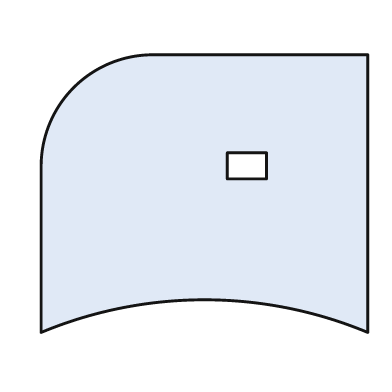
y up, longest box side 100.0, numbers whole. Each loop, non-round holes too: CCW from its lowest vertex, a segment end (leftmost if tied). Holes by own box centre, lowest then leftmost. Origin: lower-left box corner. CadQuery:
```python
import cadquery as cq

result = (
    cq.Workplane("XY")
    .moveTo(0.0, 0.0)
    .threePointArc((50.0, 10.0), (100.0, 0.0))
    .lineTo(100.0, 85.0)
    .lineTo(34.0, 85.0)
    .threePointArc((10.0, 75.0), (0.0, 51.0))
    .close()
    .moveTo(57.0, 47.0)
    .lineTo(69.0, 47.0)
    .lineTo(69.0, 55.0)
    .lineTo(57.0, 55.0)
    .close()
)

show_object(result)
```